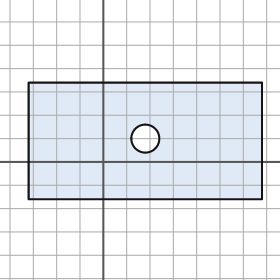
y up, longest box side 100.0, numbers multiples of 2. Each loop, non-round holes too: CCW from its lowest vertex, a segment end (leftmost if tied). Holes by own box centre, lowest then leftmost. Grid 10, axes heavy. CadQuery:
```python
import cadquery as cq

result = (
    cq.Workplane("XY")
    .moveTo(-32.0, -16.0)
    .lineTo(68.0, -16.0)
    .lineTo(68.0, 34.0)
    .lineTo(-32.0, 34.0)
    .close()
    .moveTo(18.0, 10.0)
    .circle(6.0)
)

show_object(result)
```